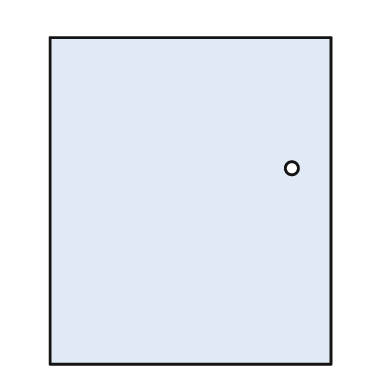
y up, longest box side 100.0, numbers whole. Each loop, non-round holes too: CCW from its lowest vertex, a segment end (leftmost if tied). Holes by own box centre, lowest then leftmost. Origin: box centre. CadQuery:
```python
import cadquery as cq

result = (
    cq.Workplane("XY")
    .moveTo(-43.0, -50.0)
    .lineTo(43.0, -50.0)
    .lineTo(43.0, 50.0)
    .lineTo(-43.0, 50.0)
    .close()
    .moveTo(31.0, 10.0)
    .circle(2.0)
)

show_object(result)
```